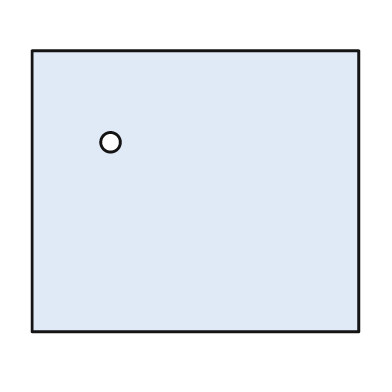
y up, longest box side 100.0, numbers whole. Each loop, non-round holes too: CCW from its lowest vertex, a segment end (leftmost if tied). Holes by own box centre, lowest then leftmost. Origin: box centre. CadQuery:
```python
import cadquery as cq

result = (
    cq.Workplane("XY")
    .moveTo(-50.0, -43.0)
    .lineTo(50.0, -43.0)
    .lineTo(50.0, 43.0)
    .lineTo(-50.0, 43.0)
    .close()
    .moveTo(-26.0, 15.0)
    .circle(3.0)
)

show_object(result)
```